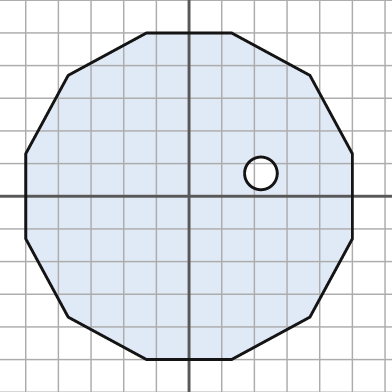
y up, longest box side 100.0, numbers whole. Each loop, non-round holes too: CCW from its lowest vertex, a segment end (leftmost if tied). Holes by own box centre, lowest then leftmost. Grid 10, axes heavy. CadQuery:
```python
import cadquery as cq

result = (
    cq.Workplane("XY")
    .moveTo(-13.0, -50.0)
    .lineTo(13.0, -50.0)
    .lineTo(37.0, -37.0)
    .lineTo(50.0, -13.0)
    .lineTo(50.0, 13.0)
    .lineTo(37.0, 37.0)
    .lineTo(13.0, 50.0)
    .lineTo(-13.0, 50.0)
    .lineTo(-37.0, 37.0)
    .lineTo(-50.0, 13.0)
    .lineTo(-50.0, -13.0)
    .lineTo(-37.0, -37.0)
    .close()
    .moveTo(22.0, 7.0)
    .circle(5.0)
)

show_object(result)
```